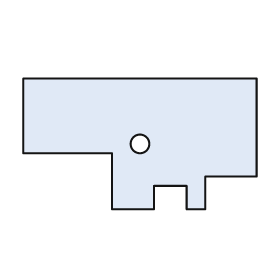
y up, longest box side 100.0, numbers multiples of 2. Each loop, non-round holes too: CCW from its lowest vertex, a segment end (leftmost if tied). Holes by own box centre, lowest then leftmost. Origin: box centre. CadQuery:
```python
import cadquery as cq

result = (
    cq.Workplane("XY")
    .moveTo(-12.0, -28.0)
    .lineTo(6.0, -28.0)
    .lineTo(6.0, -18.0)
    .lineTo(20.0, -18.0)
    .lineTo(20.0, -28.0)
    .lineTo(28.0, -28.0)
    .lineTo(28.0, -14.0)
    .lineTo(50.0, -14.0)
    .lineTo(50.0, 28.0)
    .lineTo(-50.0, 28.0)
    .lineTo(-50.0, -4.0)
    .lineTo(-12.0, -4.0)
    .close()
    .moveTo(0.0, 0.0)
    .circle(4.0)
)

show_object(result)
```